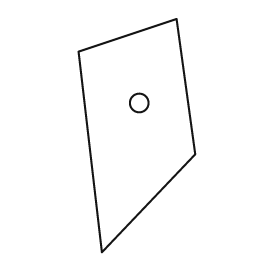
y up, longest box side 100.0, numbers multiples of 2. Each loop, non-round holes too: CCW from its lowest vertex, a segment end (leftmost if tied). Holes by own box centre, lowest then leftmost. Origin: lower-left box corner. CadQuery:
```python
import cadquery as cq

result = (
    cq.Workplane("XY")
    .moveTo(10.0, 0.0)
    .lineTo(50.0, 42.0)
    .lineTo(42.0, 100.0)
    .lineTo(0.0, 86.0)
    .close()
    .moveTo(26.0, 64.0)
    .circle(4.0)
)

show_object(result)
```